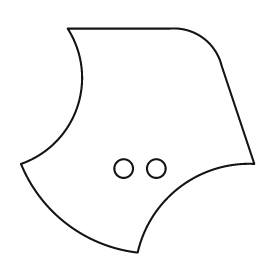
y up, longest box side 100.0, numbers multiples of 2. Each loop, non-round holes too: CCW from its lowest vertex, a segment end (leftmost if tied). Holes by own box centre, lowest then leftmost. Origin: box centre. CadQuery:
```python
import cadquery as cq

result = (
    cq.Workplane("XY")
    .moveTo(0.0, -48.0)
    .threePointArc((18.0, -20.0), (50.0, -10.0))
    .lineTo(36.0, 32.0)
    .threePointArc((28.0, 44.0), (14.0, 48.0))
    .lineTo(-30.0, 48.0)
    .threePointArc((-26.0, 14.0), (-50.0, -10.0))
    .threePointArc((-30.0, -36.0), (0.0, -48.0))
    .close()
    .moveTo(-6.0, -12.0)
    .circle(4.0)
    .moveTo(8.0, -12.0)
    .circle(4.0)
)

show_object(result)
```